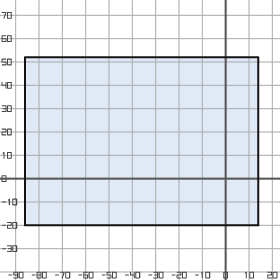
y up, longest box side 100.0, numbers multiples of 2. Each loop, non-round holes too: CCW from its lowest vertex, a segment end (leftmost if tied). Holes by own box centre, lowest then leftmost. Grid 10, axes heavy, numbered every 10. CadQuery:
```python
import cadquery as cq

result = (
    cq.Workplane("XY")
    .moveTo(-86.0, -20.0)
    .lineTo(14.0, -20.0)
    .lineTo(14.0, 52.0)
    .lineTo(-86.0, 52.0)
    .close()
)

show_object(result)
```